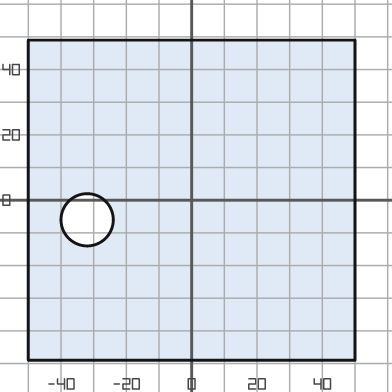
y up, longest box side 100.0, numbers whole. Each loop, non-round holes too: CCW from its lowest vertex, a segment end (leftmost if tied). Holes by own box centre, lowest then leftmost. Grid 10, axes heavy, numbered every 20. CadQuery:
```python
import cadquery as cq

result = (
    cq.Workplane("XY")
    .moveTo(-50.0, -49.0)
    .lineTo(50.0, -49.0)
    .lineTo(50.0, 49.0)
    .lineTo(-50.0, 49.0)
    .close()
    .moveTo(-32.0, -6.0)
    .circle(8.0)
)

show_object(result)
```